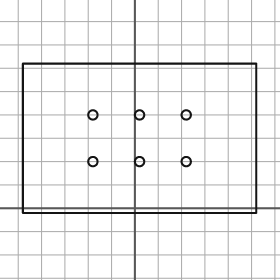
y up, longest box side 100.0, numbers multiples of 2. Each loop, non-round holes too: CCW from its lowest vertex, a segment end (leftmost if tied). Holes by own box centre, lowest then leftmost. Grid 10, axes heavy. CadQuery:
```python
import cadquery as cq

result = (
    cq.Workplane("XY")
    .moveTo(-48.0, -2.0)
    .lineTo(52.0, -2.0)
    .lineTo(52.0, 62.0)
    .lineTo(-48.0, 62.0)
    .close()
    .moveTo(-18.0, 20.0)
    .circle(2.0)
    .moveTo(2.0, 20.0)
    .circle(2.0)
    .moveTo(22.0, 20.0)
    .circle(2.0)
    .moveTo(-18.0, 40.0)
    .circle(2.0)
    .moveTo(2.0, 40.0)
    .circle(2.0)
    .moveTo(22.0, 40.0)
    .circle(2.0)
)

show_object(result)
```